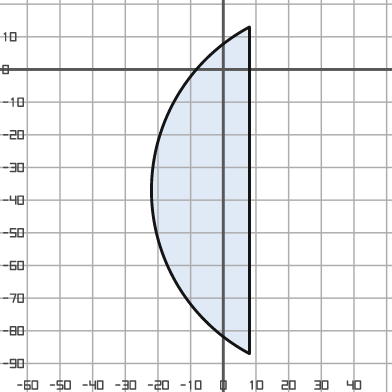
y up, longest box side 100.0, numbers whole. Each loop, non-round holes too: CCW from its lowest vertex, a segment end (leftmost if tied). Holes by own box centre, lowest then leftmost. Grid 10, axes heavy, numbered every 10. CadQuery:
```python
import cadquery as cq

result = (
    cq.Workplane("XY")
    .moveTo(8.0, -87.0)
    .lineTo(8.0, 13.0)
    .threePointArc((-22.0, -37.0), (8.0, -87.0))
    .close()
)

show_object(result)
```